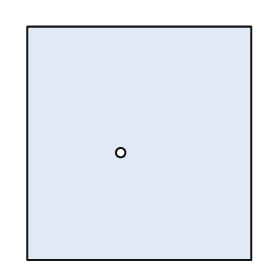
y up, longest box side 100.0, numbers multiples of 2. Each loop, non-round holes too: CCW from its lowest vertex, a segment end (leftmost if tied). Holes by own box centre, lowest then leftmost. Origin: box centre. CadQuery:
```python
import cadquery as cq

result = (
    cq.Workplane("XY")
    .moveTo(-48.0, -50.0)
    .lineTo(48.0, -50.0)
    .lineTo(48.0, 50.0)
    .lineTo(-48.0, 50.0)
    .close()
    .moveTo(-8.0, -4.0)
    .circle(2.0)
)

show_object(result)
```